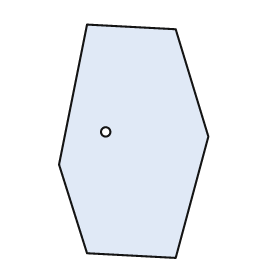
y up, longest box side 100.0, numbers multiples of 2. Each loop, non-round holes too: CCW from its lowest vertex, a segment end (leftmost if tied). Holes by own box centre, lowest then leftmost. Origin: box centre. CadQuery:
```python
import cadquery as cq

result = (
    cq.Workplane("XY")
    .moveTo(18.0, -50.0)
    .lineTo(32.0, 2.0)
    .lineTo(18.0, 48.0)
    .lineTo(-20.0, 50.0)
    .lineTo(-32.0, -10.0)
    .lineTo(-20.0, -48.0)
    .close()
    .moveTo(-12.0, 4.0)
    .circle(2.0)
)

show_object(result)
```